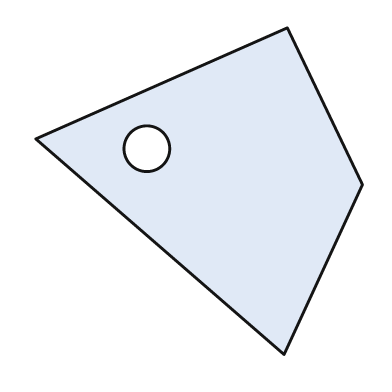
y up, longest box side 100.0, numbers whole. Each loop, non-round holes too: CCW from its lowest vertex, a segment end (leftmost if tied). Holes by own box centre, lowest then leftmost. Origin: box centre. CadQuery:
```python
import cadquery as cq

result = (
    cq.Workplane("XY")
    .moveTo(26.0, -50.0)
    .lineTo(50.0, 2.0)
    .lineTo(27.0, 50.0)
    .lineTo(-50.0, 16.0)
    .close()
    .moveTo(-16.0, 13.0)
    .circle(7.0)
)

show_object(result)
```